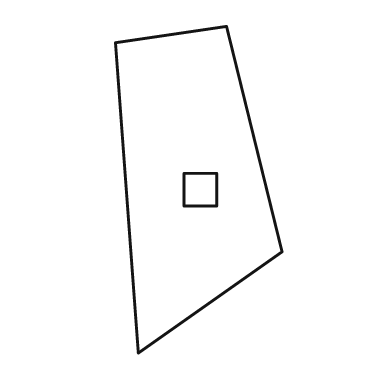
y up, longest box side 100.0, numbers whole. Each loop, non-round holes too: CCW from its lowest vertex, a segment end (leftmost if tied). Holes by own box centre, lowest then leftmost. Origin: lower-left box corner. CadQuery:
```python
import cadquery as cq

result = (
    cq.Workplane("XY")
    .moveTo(7.0, 0.0)
    .lineTo(51.0, 31.0)
    .lineTo(34.0, 100.0)
    .lineTo(0.0, 95.0)
    .close()
    .moveTo(21.0, 45.0)
    .lineTo(31.0, 45.0)
    .lineTo(31.0, 55.0)
    .lineTo(21.0, 55.0)
    .close()
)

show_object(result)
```